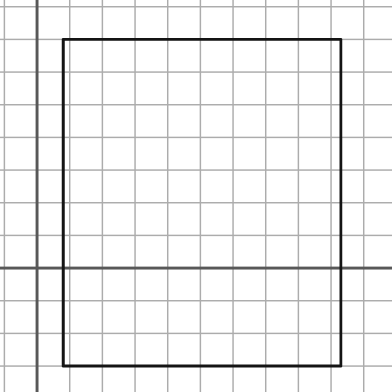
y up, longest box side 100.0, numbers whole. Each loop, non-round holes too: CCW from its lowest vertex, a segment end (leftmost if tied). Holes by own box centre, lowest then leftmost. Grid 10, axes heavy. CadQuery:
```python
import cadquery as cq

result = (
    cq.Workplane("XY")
    .moveTo(8.0, -30.0)
    .lineTo(93.0, -30.0)
    .lineTo(93.0, 70.0)
    .lineTo(8.0, 70.0)
    .close()
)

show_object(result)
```